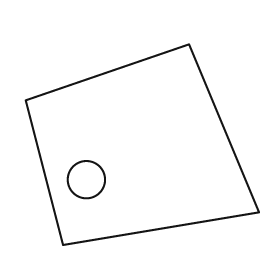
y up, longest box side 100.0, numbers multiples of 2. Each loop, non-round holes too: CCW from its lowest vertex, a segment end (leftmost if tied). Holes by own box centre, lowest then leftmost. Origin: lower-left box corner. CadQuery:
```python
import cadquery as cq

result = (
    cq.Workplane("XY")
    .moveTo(16.0, 0.0)
    .lineTo(100.0, 14.0)
    .lineTo(70.0, 86.0)
    .lineTo(0.0, 62.0)
    .close()
    .moveTo(26.0, 28.0)
    .circle(8.0)
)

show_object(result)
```